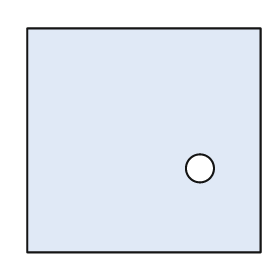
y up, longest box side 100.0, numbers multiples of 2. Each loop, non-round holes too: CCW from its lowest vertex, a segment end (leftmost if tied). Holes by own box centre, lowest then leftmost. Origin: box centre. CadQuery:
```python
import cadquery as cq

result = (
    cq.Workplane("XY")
    .moveTo(-50.0, -48.0)
    .lineTo(50.0, -48.0)
    .lineTo(50.0, 48.0)
    .lineTo(-50.0, 48.0)
    .close()
    .moveTo(24.0, -12.0)
    .circle(6.0)
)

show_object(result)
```